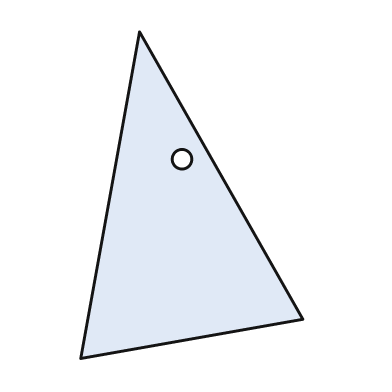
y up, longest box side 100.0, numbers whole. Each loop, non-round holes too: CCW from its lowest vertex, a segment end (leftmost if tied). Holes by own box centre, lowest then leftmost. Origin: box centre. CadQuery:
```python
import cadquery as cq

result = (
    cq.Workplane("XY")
    .moveTo(-34.0, -50.0)
    .lineTo(34.0, -38.0)
    .lineTo(-16.0, 50.0)
    .close()
    .moveTo(-3.0, 11.0)
    .circle(3.0)
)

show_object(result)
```